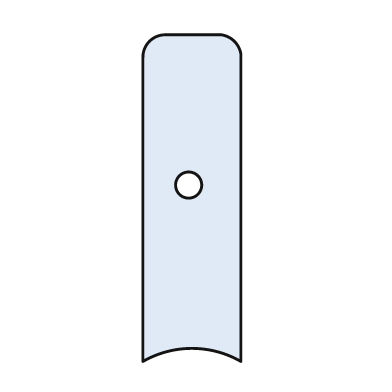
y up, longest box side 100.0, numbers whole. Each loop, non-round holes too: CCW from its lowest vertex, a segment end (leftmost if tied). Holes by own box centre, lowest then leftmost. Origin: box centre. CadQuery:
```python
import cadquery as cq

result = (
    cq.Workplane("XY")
    .moveTo(-15.0, -50.0)
    .threePointArc((0.0, -46.0), (15.0, -50.0))
    .lineTo(15.0, 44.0)
    .threePointArc((13.0, 48.0), (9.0, 50.0))
    .lineTo(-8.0, 50.0)
    .threePointArc((-13.0, 48.0), (-15.0, 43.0))
    .close()
    .moveTo(-1.0, 4.0)
    .circle(4.0)
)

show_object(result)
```